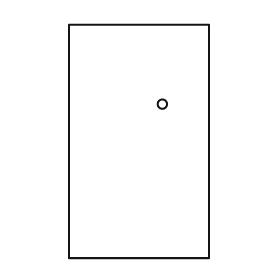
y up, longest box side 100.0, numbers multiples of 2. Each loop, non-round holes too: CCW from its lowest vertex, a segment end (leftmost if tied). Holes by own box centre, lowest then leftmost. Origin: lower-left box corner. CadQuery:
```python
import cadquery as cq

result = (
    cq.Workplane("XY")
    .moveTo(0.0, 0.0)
    .lineTo(60.0, 0.0)
    .lineTo(60.0, 100.0)
    .lineTo(0.0, 100.0)
    .close()
    .moveTo(40.0, 66.0)
    .circle(2.0)
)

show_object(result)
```